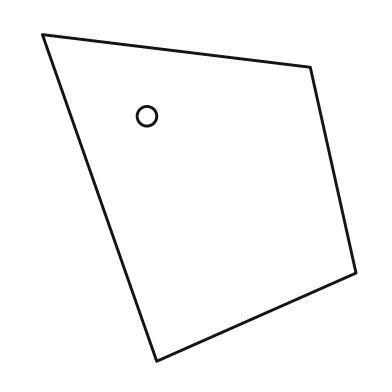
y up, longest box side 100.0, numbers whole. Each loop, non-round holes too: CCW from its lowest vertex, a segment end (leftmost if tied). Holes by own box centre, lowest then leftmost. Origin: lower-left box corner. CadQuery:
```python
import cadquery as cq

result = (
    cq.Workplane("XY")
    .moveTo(35.0, 0.0)
    .lineTo(96.0, 27.0)
    .lineTo(82.0, 90.0)
    .lineTo(0.0, 100.0)
    .close()
    .moveTo(32.0, 75.0)
    .circle(3.0)
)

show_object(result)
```